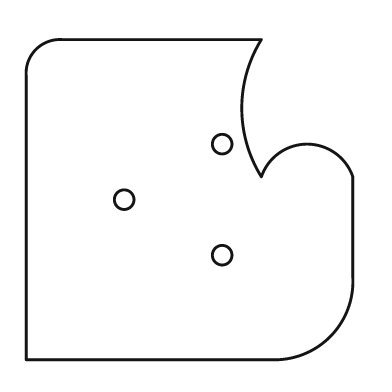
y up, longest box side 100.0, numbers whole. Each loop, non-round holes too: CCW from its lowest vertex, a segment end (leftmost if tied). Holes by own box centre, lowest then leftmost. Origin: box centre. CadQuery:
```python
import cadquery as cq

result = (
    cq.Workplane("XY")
    .moveTo(-50.0, -49.0)
    .lineTo(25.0, -49.0)
    .threePointArc((43.0, -42.0), (50.0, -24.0))
    .lineTo(50.0, 7.0)
    .threePointArc((36.0, 17.0), (22.0, 7.0))
    .threePointArc((16.0, 28.0), (22.0, 49.0))
    .lineTo(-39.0, 49.0)
    .threePointArc((-47.0, 46.0), (-50.0, 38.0))
    .close()
    .moveTo(10.0, -17.0)
    .circle(3.0)
    .moveTo(-20.0, 0.0)
    .circle(3.0)
    .moveTo(10.0, 17.0)
    .circle(3.0)
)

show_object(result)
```